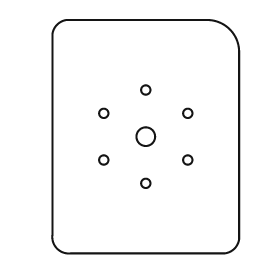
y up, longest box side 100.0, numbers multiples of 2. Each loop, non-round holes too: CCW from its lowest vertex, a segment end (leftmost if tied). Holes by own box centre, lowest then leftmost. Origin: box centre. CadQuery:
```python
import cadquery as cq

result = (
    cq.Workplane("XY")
    .moveTo(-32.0, -50.0)
    .lineTo(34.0, -50.0)
    .threePointArc((38.0, -48.0), (40.0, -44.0))
    .lineTo(40.0, 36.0)
    .threePointArc((36.0, 46.0), (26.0, 50.0))
    .lineTo(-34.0, 50.0)
    .threePointArc((-38.0, 48.0), (-40.0, 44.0))
    .lineTo(-40.0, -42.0)
    .threePointArc((-38.0, -48.0), (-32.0, -50.0))
    .close()
    .moveTo(0.0, -20.0)
    .circle(2.0)
    .moveTo(-18.0, -10.0)
    .circle(2.0)
    .moveTo(18.0, -10.0)
    .circle(2.0)
    .moveTo(0.0, 0.0)
    .circle(4.0)
    .moveTo(-18.0, 10.0)
    .circle(2.0)
    .moveTo(18.0, 10.0)
    .circle(2.0)
    .moveTo(0.0, 20.0)
    .circle(2.0)
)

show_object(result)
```